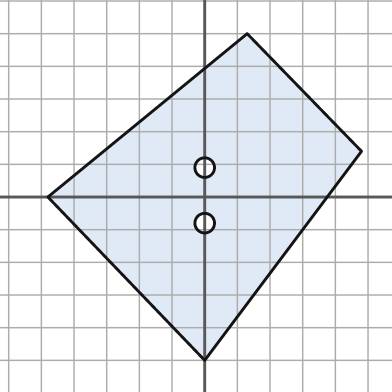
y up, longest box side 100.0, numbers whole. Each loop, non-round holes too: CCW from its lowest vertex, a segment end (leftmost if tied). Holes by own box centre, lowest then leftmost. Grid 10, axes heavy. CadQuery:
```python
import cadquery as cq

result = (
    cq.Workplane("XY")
    .moveTo(0.0, -50.0)
    .lineTo(48.0, 14.0)
    .lineTo(13.0, 50.0)
    .lineTo(-48.0, 0.0)
    .close()
    .moveTo(0.0, -8.0)
    .circle(3.0)
    .moveTo(0.0, 9.0)
    .circle(3.0)
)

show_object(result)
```